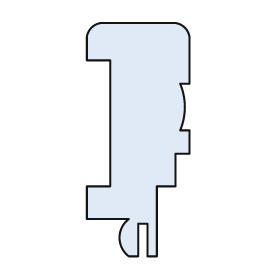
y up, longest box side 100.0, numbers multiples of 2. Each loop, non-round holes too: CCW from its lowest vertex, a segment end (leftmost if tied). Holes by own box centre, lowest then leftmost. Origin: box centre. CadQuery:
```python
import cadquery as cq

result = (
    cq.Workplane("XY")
    .moveTo(-4.0, -50.0)
    .lineTo(0.0, -50.0)
    .lineTo(0.0, -36.0)
    .lineTo(4.0, -36.0)
    .lineTo(4.0, -50.0)
    .lineTo(8.0, -50.0)
    .lineTo(8.0, -20.0)
    .lineTo(16.0, -20.0)
    .lineTo(16.0, -6.0)
    .lineTo(22.0, -6.0)
    .lineTo(22.0, 4.0)
    .lineTo(18.0, 4.0)
    .threePointArc((20.0, 14.0), (18.0, 24.0))
    .lineTo(22.0, 24.0)
    .lineTo(22.0, 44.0)
    .threePointArc((20.0, 48.0), (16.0, 50.0))
    .lineTo(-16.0, 50.0)
    .threePointArc((-20.0, 48.0), (-22.0, 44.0))
    .lineTo(-22.0, 34.0)
    .lineTo(-12.0, 34.0)
    .lineTo(-12.0, -20.0)
    .lineTo(-22.0, -20.0)
    .lineTo(-22.0, -34.0)
    .lineTo(-4.0, -34.0)
    .threePointArc((-8.0, -42.0), (-4.0, -50.0))
    .close()
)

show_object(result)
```